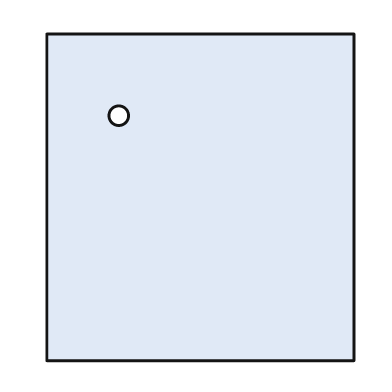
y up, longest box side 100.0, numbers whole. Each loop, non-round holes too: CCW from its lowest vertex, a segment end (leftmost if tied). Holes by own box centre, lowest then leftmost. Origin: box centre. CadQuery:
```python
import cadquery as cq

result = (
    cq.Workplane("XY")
    .moveTo(-47.0, -50.0)
    .lineTo(47.0, -50.0)
    .lineTo(47.0, 50.0)
    .lineTo(-47.0, 50.0)
    .close()
    .moveTo(-25.0, 25.0)
    .circle(3.0)
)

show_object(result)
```